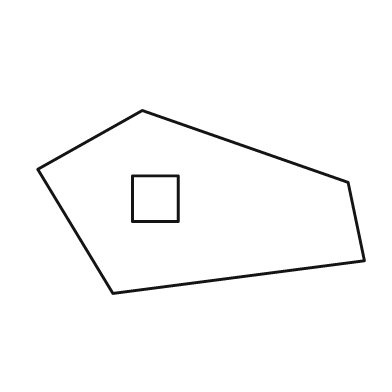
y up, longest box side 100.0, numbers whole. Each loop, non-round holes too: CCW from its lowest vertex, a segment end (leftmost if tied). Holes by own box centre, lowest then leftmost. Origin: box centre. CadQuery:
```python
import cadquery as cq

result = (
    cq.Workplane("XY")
    .moveTo(-27.0, -28.0)
    .lineTo(50.0, -18.0)
    .lineTo(45.0, 6.0)
    .lineTo(-18.0, 28.0)
    .lineTo(-50.0, 10.0)
    .close()
    .moveTo(-21.0, -6.0)
    .lineTo(-7.0, -6.0)
    .lineTo(-7.0, 8.0)
    .lineTo(-21.0, 8.0)
    .close()
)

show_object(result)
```